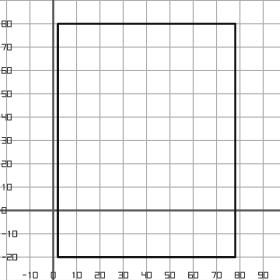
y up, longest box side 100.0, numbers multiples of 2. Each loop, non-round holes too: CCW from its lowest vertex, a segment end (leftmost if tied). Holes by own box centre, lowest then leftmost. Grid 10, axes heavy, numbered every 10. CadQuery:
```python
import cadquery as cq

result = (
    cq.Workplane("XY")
    .moveTo(2.0, -20.0)
    .lineTo(78.0, -20.0)
    .lineTo(78.0, 80.0)
    .lineTo(2.0, 80.0)
    .close()
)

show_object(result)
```